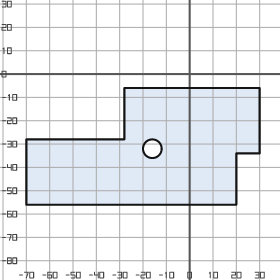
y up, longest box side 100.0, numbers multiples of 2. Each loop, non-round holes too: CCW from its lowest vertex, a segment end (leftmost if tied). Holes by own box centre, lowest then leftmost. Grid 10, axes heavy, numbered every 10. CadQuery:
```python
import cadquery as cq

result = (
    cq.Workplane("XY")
    .moveTo(-70.0, -56.0)
    .lineTo(20.0, -56.0)
    .lineTo(20.0, -34.0)
    .lineTo(30.0, -34.0)
    .lineTo(30.0, -6.0)
    .lineTo(-28.0, -6.0)
    .lineTo(-28.0, -28.0)
    .lineTo(-70.0, -28.0)
    .close()
    .moveTo(-16.0, -32.0)
    .circle(4.0)
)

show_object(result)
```